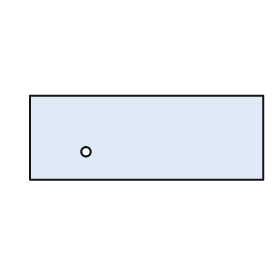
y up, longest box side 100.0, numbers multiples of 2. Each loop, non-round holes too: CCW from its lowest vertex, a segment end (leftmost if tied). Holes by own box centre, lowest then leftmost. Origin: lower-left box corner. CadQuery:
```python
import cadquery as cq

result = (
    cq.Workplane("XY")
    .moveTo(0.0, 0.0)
    .lineTo(100.0, 0.0)
    .lineTo(100.0, 36.0)
    .lineTo(0.0, 36.0)
    .close()
    .moveTo(24.0, 12.0)
    .circle(2.0)
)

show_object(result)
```